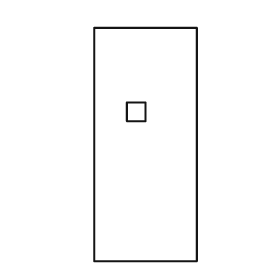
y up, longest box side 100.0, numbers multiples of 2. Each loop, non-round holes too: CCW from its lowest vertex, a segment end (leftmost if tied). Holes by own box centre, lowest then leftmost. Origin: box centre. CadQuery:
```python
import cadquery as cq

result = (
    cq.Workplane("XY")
    .moveTo(-22.0, -50.0)
    .lineTo(22.0, -50.0)
    .lineTo(22.0, 50.0)
    .lineTo(-22.0, 50.0)
    .close()
    .moveTo(-8.0, 10.0)
    .lineTo(0.0, 10.0)
    .lineTo(0.0, 18.0)
    .lineTo(-8.0, 18.0)
    .close()
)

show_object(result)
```